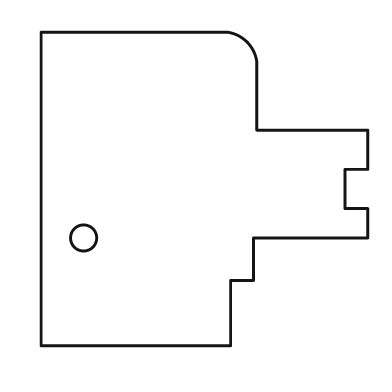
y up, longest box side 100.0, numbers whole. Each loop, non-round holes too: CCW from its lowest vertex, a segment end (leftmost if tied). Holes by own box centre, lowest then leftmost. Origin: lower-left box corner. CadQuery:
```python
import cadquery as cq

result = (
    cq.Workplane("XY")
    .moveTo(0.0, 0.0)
    .lineTo(58.0, 0.0)
    .lineTo(58.0, 20.0)
    .lineTo(65.0, 20.0)
    .lineTo(65.0, 33.0)
    .lineTo(100.0, 33.0)
    .lineTo(100.0, 42.0)
    .lineTo(93.0, 42.0)
    .lineTo(93.0, 54.0)
    .lineTo(100.0, 54.0)
    .lineTo(100.0, 66.0)
    .lineTo(66.0, 66.0)
    .lineTo(66.0, 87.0)
    .threePointArc((63.0, 93.0), (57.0, 96.0))
    .lineTo(0.0, 96.0)
    .close()
    .moveTo(13.0, 33.0)
    .circle(4.0)
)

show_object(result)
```